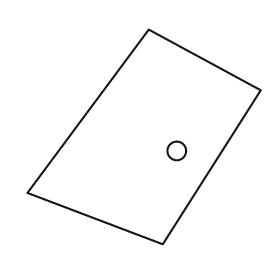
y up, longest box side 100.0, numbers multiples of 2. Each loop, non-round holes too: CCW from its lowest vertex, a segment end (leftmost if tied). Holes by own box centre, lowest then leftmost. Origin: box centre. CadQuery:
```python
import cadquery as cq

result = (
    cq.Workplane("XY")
    .moveTo(8.0, -46.0)
    .lineTo(50.0, 20.0)
    .lineTo(2.0, 46.0)
    .lineTo(-50.0, -24.0)
    .close()
    .moveTo(14.0, -6.0)
    .circle(4.0)
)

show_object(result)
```